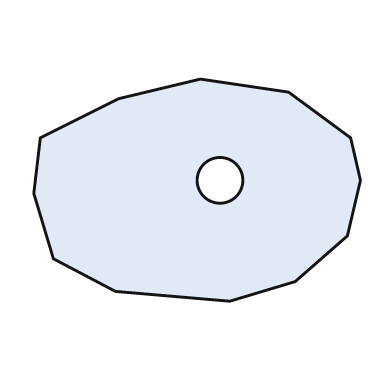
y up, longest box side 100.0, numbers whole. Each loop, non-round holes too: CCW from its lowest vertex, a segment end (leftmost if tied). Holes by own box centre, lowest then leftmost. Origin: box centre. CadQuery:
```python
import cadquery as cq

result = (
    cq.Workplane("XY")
    .moveTo(10.0, -34.0)
    .lineTo(30.0, -28.0)
    .lineTo(46.0, -14.0)
    .lineTo(50.0, 3.0)
    .lineTo(47.0, 16.0)
    .lineTo(28.0, 30.0)
    .lineTo(1.0, 34.0)
    .lineTo(-24.0, 28.0)
    .lineTo(-48.0, 16.0)
    .lineTo(-50.0, -1.0)
    .lineTo(-44.0, -21.0)
    .lineTo(-25.0, -31.0)
    .close()
    .moveTo(7.0, 3.0)
    .circle(7.0)
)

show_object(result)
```